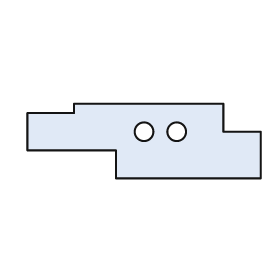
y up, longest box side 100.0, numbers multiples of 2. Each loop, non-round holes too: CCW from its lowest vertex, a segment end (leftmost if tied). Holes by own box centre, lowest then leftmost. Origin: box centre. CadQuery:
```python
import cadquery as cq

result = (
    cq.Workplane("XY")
    .moveTo(-12.0, -16.0)
    .lineTo(50.0, -16.0)
    .lineTo(50.0, 4.0)
    .lineTo(34.0, 4.0)
    .lineTo(34.0, 16.0)
    .lineTo(-30.0, 16.0)
    .lineTo(-30.0, 12.0)
    .lineTo(-50.0, 12.0)
    .lineTo(-50.0, -4.0)
    .lineTo(-12.0, -4.0)
    .close()
    .moveTo(0.0, 4.0)
    .circle(4.0)
    .moveTo(14.0, 4.0)
    .circle(4.0)
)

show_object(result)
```